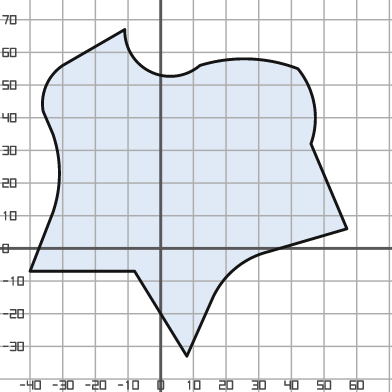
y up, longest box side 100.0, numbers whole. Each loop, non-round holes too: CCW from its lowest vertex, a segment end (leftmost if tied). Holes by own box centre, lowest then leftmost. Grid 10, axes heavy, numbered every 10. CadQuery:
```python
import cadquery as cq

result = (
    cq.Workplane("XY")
    .moveTo(8.0, -33.0)
    .lineTo(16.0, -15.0)
    .threePointArc((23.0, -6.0), (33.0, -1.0))
    .lineTo(57.0, 6.0)
    .lineTo(46.0, 32.0)
    .threePointArc((47.0, 44.0), (42.0, 55.0))
    .threePointArc((27.0, 58.0), (12.0, 56.0))
    .threePointArc((-3.0, 54.0), (-11.0, 67.0))
    .lineTo(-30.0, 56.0)
    .threePointArc((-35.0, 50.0), (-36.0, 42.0))
    .lineTo(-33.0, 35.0)
    .threePointArc((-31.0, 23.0), (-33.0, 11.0))
    .lineTo(-40.0, -7.0)
    .lineTo(-8.0, -7.0)
    .close()
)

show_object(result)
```